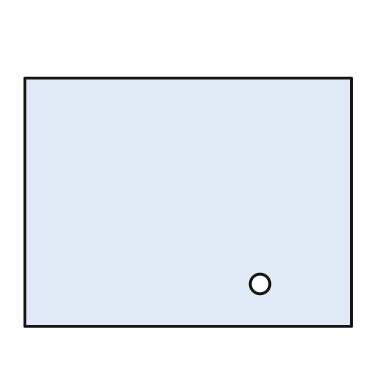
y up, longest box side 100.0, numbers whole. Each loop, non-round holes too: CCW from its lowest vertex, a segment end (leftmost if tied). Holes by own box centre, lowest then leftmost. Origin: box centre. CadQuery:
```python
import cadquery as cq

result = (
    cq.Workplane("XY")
    .moveTo(-50.0, -38.0)
    .lineTo(50.0, -38.0)
    .lineTo(50.0, 38.0)
    .lineTo(-50.0, 38.0)
    .close()
    .moveTo(22.0, -25.0)
    .circle(3.0)
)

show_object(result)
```